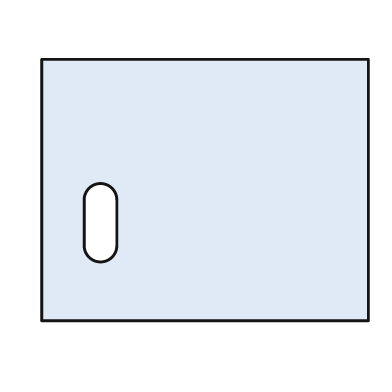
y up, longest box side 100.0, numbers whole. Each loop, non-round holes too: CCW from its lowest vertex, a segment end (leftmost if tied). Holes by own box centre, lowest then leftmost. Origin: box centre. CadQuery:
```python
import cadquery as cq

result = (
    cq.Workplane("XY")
    .moveTo(-50.0, -40.0)
    .lineTo(50.0, -40.0)
    .lineTo(50.0, 40.0)
    .lineTo(-50.0, 40.0)
    .close()
    .moveTo(-37.0, -17.0)
    .threePointArc((-32.0, -22.0), (-27.0, -17.0))
    .lineTo(-27.0, -3.0)
    .threePointArc((-32.0, 2.0), (-37.0, -3.0))
    .close()
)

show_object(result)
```